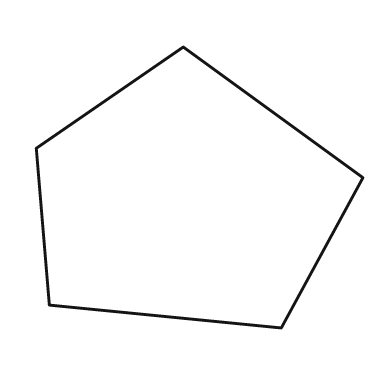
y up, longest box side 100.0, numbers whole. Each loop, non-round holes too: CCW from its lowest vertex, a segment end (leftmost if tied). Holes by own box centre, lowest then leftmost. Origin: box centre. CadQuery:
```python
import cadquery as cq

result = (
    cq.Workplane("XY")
    .moveTo(25.0, -43.0)
    .lineTo(50.0, 3.0)
    .lineTo(-5.0, 43.0)
    .lineTo(-50.0, 12.0)
    .lineTo(-46.0, -36.0)
    .close()
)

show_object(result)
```